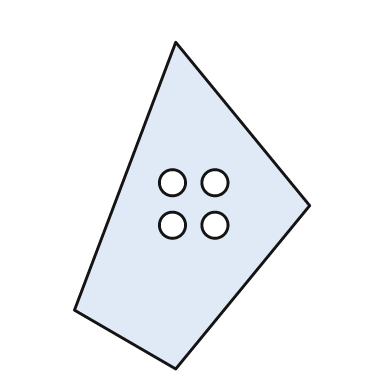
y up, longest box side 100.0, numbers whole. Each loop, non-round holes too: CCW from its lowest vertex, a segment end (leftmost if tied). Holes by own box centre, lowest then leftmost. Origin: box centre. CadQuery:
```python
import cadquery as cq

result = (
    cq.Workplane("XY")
    .moveTo(-5.0, -50.0)
    .lineTo(36.0, 0.0)
    .lineTo(-5.0, 50.0)
    .lineTo(-36.0, -32.0)
    .close()
    .moveTo(-6.0, -6.0)
    .circle(4.0)
    .moveTo(7.0, -6.0)
    .circle(4.0)
    .moveTo(-6.0, 7.0)
    .circle(4.0)
    .moveTo(7.0, 7.0)
    .circle(4.0)
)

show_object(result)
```